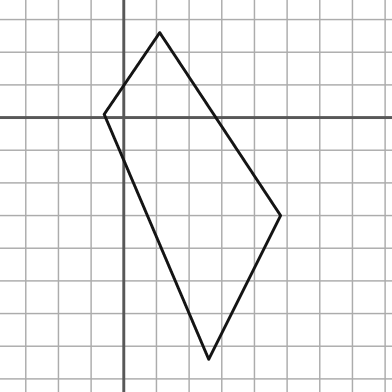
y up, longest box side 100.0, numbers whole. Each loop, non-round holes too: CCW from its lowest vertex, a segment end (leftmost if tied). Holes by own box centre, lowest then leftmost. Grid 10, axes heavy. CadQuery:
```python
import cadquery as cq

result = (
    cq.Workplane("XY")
    .moveTo(26.0, -74.0)
    .lineTo(48.0, -30.0)
    .lineTo(11.0, 26.0)
    .lineTo(-6.0, 1.0)
    .close()
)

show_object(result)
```